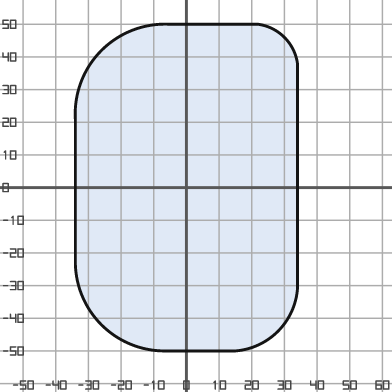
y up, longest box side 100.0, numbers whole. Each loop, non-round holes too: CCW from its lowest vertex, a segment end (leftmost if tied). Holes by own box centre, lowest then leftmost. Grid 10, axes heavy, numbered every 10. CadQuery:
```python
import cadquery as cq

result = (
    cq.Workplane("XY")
    .moveTo(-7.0, -50.0)
    .lineTo(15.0, -50.0)
    .threePointArc((28.0, -44.0), (34.0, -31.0))
    .lineTo(34.0, 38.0)
    .threePointArc((30.0, 46.0), (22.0, 50.0))
    .lineTo(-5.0, 50.0)
    .threePointArc((-26.0, 42.0), (-34.0, 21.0))
    .lineTo(-34.0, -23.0)
    .threePointArc((-26.0, -42.0), (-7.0, -50.0))
    .close()
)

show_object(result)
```